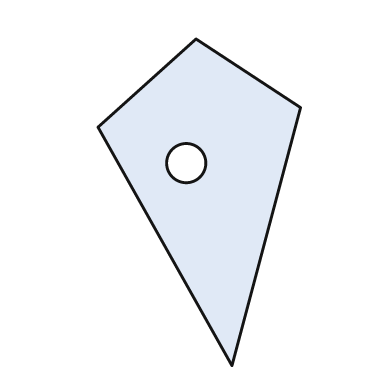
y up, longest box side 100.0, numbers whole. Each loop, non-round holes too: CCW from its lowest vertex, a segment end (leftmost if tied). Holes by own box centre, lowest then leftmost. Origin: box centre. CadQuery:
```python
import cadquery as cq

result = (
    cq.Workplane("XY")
    .moveTo(10.0, -50.0)
    .lineTo(31.0, 29.0)
    .lineTo(-1.0, 50.0)
    .lineTo(-31.0, 23.0)
    .close()
    .moveTo(-4.0, 12.0)
    .circle(6.0)
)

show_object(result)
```